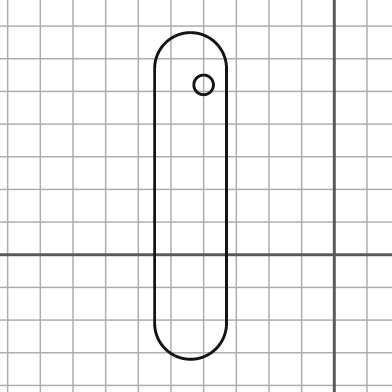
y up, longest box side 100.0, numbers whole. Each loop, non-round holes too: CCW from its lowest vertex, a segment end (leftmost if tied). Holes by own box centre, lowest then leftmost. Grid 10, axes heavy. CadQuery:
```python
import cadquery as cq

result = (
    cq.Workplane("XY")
    .moveTo(-55.0, -21.0)
    .threePointArc((-44.0, -32.0), (-33.0, -21.0))
    .lineTo(-33.0, 57.0)
    .threePointArc((-44.0, 68.0), (-55.0, 57.0))
    .close()
    .moveTo(-40.0, 52.0)
    .circle(3.0)
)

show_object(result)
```